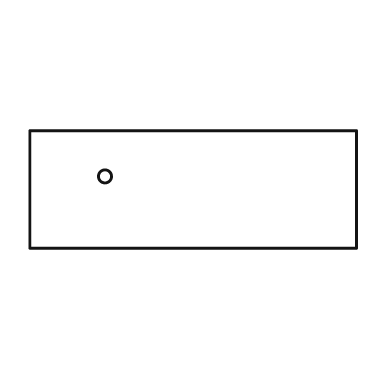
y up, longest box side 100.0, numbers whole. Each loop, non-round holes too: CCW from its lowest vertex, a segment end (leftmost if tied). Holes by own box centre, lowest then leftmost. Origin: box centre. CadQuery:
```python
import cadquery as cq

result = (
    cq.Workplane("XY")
    .moveTo(-50.0, -18.0)
    .lineTo(50.0, -18.0)
    .lineTo(50.0, 18.0)
    .lineTo(-50.0, 18.0)
    .close()
    .moveTo(-27.0, 4.0)
    .circle(2.0)
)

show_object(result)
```